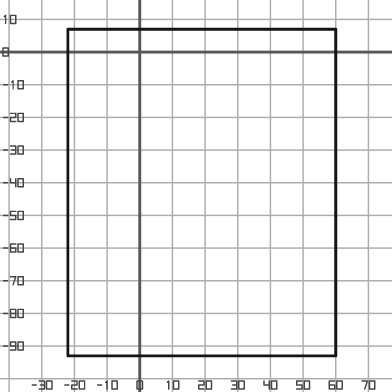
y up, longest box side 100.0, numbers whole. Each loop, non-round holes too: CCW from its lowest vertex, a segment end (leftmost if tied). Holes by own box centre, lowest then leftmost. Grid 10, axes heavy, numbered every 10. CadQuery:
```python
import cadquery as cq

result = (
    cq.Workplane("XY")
    .moveTo(-22.0, -93.0)
    .lineTo(60.0, -93.0)
    .lineTo(60.0, 7.0)
    .lineTo(-22.0, 7.0)
    .close()
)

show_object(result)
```